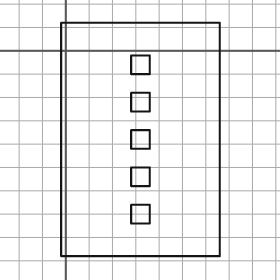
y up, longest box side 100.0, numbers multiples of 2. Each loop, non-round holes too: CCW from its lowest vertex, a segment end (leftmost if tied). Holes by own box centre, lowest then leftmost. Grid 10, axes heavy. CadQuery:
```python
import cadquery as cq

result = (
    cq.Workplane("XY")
    .moveTo(-2.0, -88.0)
    .lineTo(66.0, -88.0)
    .lineTo(66.0, 12.0)
    .lineTo(-2.0, 12.0)
    .close()
    .moveTo(28.0, -74.0)
    .lineTo(36.0, -74.0)
    .lineTo(36.0, -66.0)
    .lineTo(28.0, -66.0)
    .close()
    .moveTo(28.0, -58.0)
    .lineTo(36.0, -58.0)
    .lineTo(36.0, -50.0)
    .lineTo(28.0, -50.0)
    .close()
    .moveTo(28.0, -42.0)
    .lineTo(36.0, -42.0)
    .lineTo(36.0, -34.0)
    .lineTo(28.0, -34.0)
    .close()
    .moveTo(28.0, -26.0)
    .lineTo(36.0, -26.0)
    .lineTo(36.0, -18.0)
    .lineTo(28.0, -18.0)
    .close()
    .moveTo(28.0, -10.0)
    .lineTo(36.0, -10.0)
    .lineTo(36.0, -2.0)
    .lineTo(28.0, -2.0)
    .close()
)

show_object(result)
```